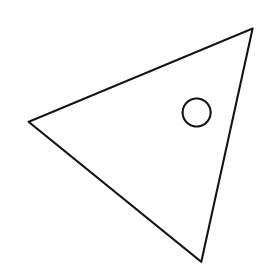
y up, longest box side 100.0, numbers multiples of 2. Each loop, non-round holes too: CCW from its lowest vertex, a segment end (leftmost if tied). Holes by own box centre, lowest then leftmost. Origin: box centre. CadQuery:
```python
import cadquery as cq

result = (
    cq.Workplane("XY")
    .moveTo(26.0, -50.0)
    .lineTo(48.0, 50.0)
    .lineTo(-48.0, 10.0)
    .close()
    .moveTo(24.0, 14.0)
    .circle(6.0)
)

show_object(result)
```